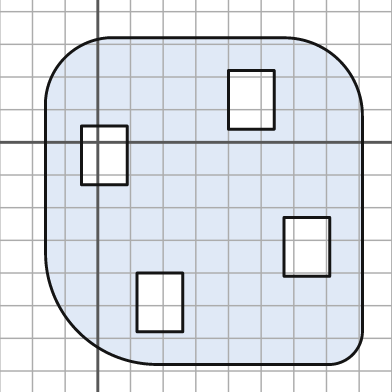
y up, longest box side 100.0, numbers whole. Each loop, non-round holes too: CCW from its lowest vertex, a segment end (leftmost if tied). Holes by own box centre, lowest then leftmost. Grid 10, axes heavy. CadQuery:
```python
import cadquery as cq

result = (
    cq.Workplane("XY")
    .moveTo(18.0, -68.0)
    .lineTo(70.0, -68.0)
    .threePointArc((78.0, -65.0), (81.0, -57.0))
    .lineTo(81.0, 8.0)
    .threePointArc((74.0, 25.0), (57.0, 32.0))
    .lineTo(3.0, 32.0)
    .threePointArc((-10.0, 26.0), (-16.0, 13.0))
    .lineTo(-16.0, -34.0)
    .threePointArc((-6.0, -58.0), (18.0, -68.0))
    .close()
    .moveTo(12.0, -58.0)
    .lineTo(26.0, -58.0)
    .lineTo(26.0, -40.0)
    .lineTo(12.0, -40.0)
    .close()
    .moveTo(57.0, -41.0)
    .lineTo(71.0, -41.0)
    .lineTo(71.0, -23.0)
    .lineTo(57.0, -23.0)
    .close()
    .moveTo(-5.0, -13.0)
    .lineTo(9.0, -13.0)
    .lineTo(9.0, 5.0)
    .lineTo(-5.0, 5.0)
    .close()
    .moveTo(40.0, 4.0)
    .lineTo(54.0, 4.0)
    .lineTo(54.0, 22.0)
    .lineTo(40.0, 22.0)
    .close()
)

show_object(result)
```